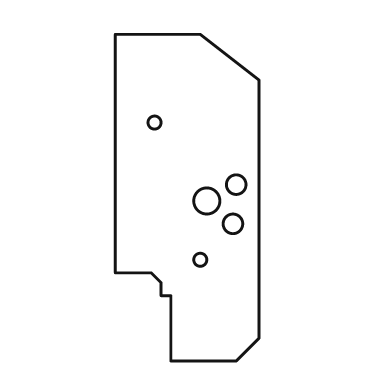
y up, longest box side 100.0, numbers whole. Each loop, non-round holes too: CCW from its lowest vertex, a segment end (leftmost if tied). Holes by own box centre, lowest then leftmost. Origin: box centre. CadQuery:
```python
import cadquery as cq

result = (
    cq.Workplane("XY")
    .moveTo(-5.0, -50.0)
    .lineTo(15.0, -50.0)
    .lineTo(22.0, -43.0)
    .lineTo(22.0, 36.0)
    .lineTo(4.0, 50.0)
    .lineTo(-22.0, 50.0)
    .lineTo(-22.0, -23.0)
    .lineTo(-11.0, -23.0)
    .lineTo(-8.0, -26.0)
    .lineTo(-8.0, -30.0)
    .lineTo(-5.0, -30.0)
    .close()
    .moveTo(4.0, -19.0)
    .circle(2.0)
    .moveTo(14.0, -8.0)
    .circle(3.0)
    .moveTo(6.0, -1.0)
    .circle(4.0)
    .moveTo(15.0, 4.0)
    .circle(3.0)
    .moveTo(-10.0, 23.0)
    .circle(2.0)
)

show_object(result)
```